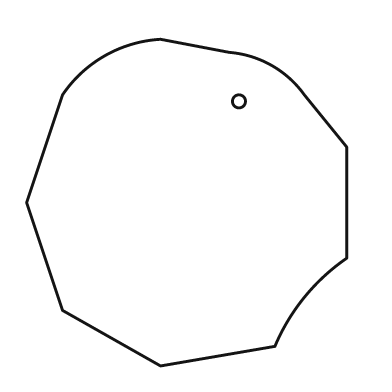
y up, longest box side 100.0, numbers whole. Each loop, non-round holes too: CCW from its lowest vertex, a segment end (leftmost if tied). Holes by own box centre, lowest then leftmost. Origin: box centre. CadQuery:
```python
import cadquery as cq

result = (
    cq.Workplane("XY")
    .moveTo(-8.0, -50.0)
    .lineTo(27.0, -44.0)
    .threePointArc((36.0, -29.0), (49.0, -17.0))
    .lineTo(49.0, 17.0)
    .lineTo(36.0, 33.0)
    .threePointArc((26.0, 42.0), (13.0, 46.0))
    .lineTo(-8.0, 50.0)
    .threePointArc((-25.0, 45.0), (-38.0, 33.0))
    .lineTo(-49.0, 0.0)
    .lineTo(-38.0, -33.0)
    .close()
    .moveTo(16.0, 31.0)
    .circle(2.0)
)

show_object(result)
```